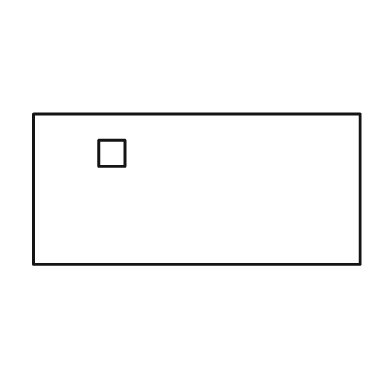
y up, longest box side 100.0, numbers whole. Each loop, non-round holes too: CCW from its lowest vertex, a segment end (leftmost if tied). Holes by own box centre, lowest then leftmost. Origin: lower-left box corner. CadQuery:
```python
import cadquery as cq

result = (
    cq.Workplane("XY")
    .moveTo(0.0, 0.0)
    .lineTo(100.0, 0.0)
    .lineTo(100.0, 46.0)
    .lineTo(0.0, 46.0)
    .close()
    .moveTo(20.0, 30.0)
    .lineTo(28.0, 30.0)
    .lineTo(28.0, 38.0)
    .lineTo(20.0, 38.0)
    .close()
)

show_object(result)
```